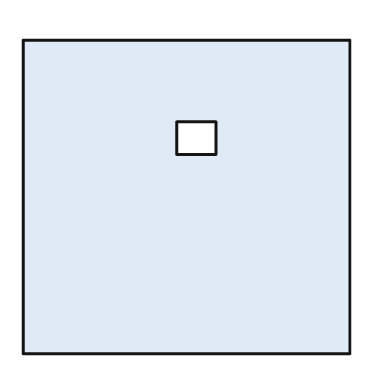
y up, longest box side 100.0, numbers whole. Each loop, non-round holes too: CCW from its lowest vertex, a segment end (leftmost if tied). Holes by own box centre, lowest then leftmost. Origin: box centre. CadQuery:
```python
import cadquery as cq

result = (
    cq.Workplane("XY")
    .moveTo(-50.0, -48.0)
    .lineTo(50.0, -48.0)
    .lineTo(50.0, 48.0)
    .lineTo(-50.0, 48.0)
    .close()
    .moveTo(-3.0, 13.0)
    .lineTo(9.0, 13.0)
    .lineTo(9.0, 23.0)
    .lineTo(-3.0, 23.0)
    .close()
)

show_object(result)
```